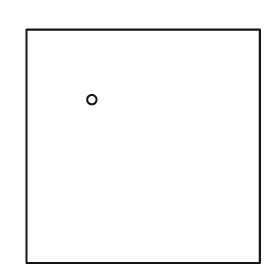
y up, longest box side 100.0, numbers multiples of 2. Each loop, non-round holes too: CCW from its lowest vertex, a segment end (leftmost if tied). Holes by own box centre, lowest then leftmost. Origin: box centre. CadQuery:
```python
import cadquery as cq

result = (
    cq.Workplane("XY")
    .moveTo(-50.0, -50.0)
    .lineTo(50.0, -50.0)
    .lineTo(50.0, 50.0)
    .lineTo(-50.0, 50.0)
    .close()
    .moveTo(-22.0, 20.0)
    .circle(2.0)
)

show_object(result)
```